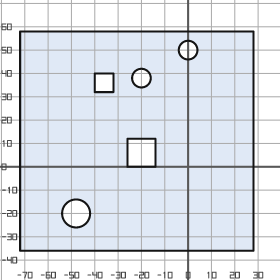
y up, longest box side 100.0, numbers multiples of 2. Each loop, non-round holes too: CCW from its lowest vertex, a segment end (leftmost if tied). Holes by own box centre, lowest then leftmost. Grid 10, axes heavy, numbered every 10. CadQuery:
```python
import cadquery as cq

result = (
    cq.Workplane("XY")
    .moveTo(-72.0, -36.0)
    .lineTo(28.0, -36.0)
    .lineTo(28.0, 58.0)
    .lineTo(-72.0, 58.0)
    .close()
    .moveTo(-48.0, -20.0)
    .circle(6.0)
    .moveTo(-26.0, 0.0)
    .lineTo(-14.0, 0.0)
    .lineTo(-14.0, 12.0)
    .lineTo(-26.0, 12.0)
    .close()
    .moveTo(-40.0, 32.0)
    .lineTo(-32.0, 32.0)
    .lineTo(-32.0, 40.0)
    .lineTo(-40.0, 40.0)
    .close()
    .moveTo(-20.0, 38.0)
    .circle(4.0)
    .moveTo(0.0, 50.0)
    .circle(4.0)
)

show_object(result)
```